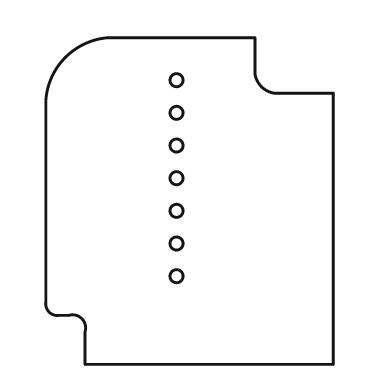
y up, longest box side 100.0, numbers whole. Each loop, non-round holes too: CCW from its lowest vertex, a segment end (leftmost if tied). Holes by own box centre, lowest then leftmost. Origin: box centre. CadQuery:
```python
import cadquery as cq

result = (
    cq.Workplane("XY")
    .moveTo(-32.0, -50.0)
    .lineTo(44.0, -50.0)
    .lineTo(44.0, 33.0)
    .lineTo(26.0, 33.0)
    .threePointArc((22.0, 35.0), (20.0, 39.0))
    .lineTo(20.0, 50.0)
    .lineTo(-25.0, 50.0)
    .threePointArc((-38.0, 44.0), (-44.0, 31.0))
    .lineTo(-44.0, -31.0)
    .threePointArc((-43.0, -34.0), (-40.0, -35.0))
    .lineTo(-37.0, -35.0)
    .threePointArc((-33.0, -36.0), (-32.0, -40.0))
    .close()
    .moveTo(-4.0, -23.0)
    .circle(2.0)
    .moveTo(-4.0, -13.0)
    .circle(2.0)
    .moveTo(-4.0, -3.0)
    .circle(2.0)
    .moveTo(-4.0, 7.0)
    .circle(2.0)
    .moveTo(-4.0, 17.0)
    .circle(2.0)
    .moveTo(-4.0, 27.0)
    .circle(2.0)
    .moveTo(-4.0, 37.0)
    .circle(2.0)
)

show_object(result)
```